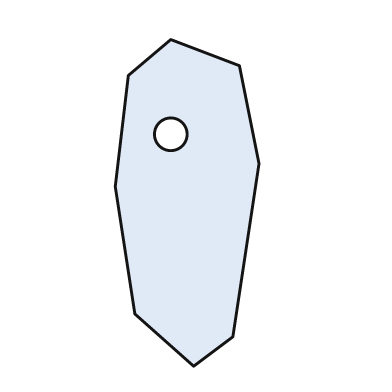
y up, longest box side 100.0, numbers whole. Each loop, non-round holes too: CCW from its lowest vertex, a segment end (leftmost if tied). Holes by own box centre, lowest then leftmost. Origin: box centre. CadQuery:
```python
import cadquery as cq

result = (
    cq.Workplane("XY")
    .moveTo(2.0, -50.0)
    .lineTo(14.0, -41.0)
    .lineTo(22.0, 12.0)
    .lineTo(16.0, 42.0)
    .lineTo(-5.0, 50.0)
    .lineTo(-18.0, 39.0)
    .lineTo(-22.0, 5.0)
    .lineTo(-16.0, -34.0)
    .close()
    .moveTo(-5.0, 21.0)
    .circle(5.0)
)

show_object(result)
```